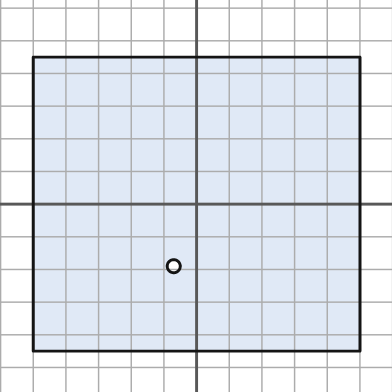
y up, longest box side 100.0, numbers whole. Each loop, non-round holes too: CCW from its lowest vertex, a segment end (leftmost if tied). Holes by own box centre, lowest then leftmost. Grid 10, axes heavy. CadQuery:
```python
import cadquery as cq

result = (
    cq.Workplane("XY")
    .moveTo(-50.0, -45.0)
    .lineTo(50.0, -45.0)
    .lineTo(50.0, 45.0)
    .lineTo(-50.0, 45.0)
    .close()
    .moveTo(-7.0, -19.0)
    .circle(2.0)
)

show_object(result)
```